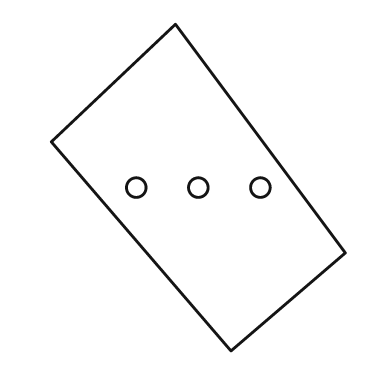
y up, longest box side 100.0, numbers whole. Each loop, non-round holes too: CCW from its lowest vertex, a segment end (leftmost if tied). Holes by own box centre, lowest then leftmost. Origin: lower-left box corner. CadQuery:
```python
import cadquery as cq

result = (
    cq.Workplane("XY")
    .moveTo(55.0, 0.0)
    .lineTo(90.0, 30.0)
    .lineTo(38.0, 100.0)
    .lineTo(0.0, 64.0)
    .close()
    .moveTo(26.0, 50.0)
    .circle(3.0)
    .moveTo(45.0, 50.0)
    .circle(3.0)
    .moveTo(64.0, 50.0)
    .circle(3.0)
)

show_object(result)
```